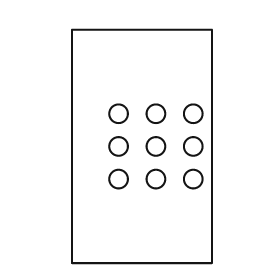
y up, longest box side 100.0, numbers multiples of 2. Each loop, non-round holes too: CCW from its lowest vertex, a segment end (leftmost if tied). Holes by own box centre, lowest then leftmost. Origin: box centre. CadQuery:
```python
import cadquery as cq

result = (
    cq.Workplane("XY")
    .moveTo(-30.0, -50.0)
    .lineTo(30.0, -50.0)
    .lineTo(30.0, 50.0)
    .lineTo(-30.0, 50.0)
    .close()
    .moveTo(-10.0, -14.0)
    .circle(4.0)
    .moveTo(6.0, -14.0)
    .circle(4.0)
    .moveTo(22.0, -14.0)
    .circle(4.0)
    .moveTo(-10.0, 0.0)
    .circle(4.0)
    .moveTo(6.0, 0.0)
    .circle(4.0)
    .moveTo(22.0, 0.0)
    .circle(4.0)
    .moveTo(-10.0, 14.0)
    .circle(4.0)
    .moveTo(6.0, 14.0)
    .circle(4.0)
    .moveTo(22.0, 14.0)
    .circle(4.0)
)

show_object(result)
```